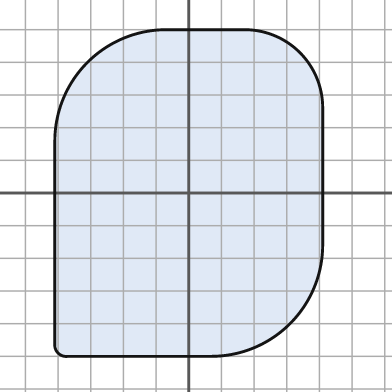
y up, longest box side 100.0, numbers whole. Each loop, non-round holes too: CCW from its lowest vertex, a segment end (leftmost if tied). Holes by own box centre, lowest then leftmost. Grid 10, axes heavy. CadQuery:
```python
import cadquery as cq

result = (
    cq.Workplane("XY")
    .moveTo(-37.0, -50.0)
    .lineTo(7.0, -50.0)
    .threePointArc((31.0, -40.0), (41.0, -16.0))
    .lineTo(41.0, 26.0)
    .threePointArc((34.0, 43.0), (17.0, 50.0))
    .lineTo(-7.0, 50.0)
    .threePointArc((-31.0, 40.0), (-41.0, 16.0))
    .lineTo(-41.0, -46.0)
    .threePointArc((-40.0, -49.0), (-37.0, -50.0))
    .close()
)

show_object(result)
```